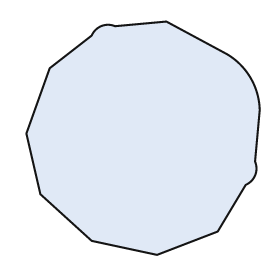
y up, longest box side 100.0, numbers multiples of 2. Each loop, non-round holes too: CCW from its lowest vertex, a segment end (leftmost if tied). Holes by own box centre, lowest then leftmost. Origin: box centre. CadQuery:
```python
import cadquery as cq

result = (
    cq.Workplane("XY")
    .moveTo(6.0, -50.0)
    .lineTo(32.0, -40.0)
    .lineTo(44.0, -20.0)
    .threePointArc((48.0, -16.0), (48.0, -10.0))
    .lineTo(50.0, 12.0)
    .threePointArc((46.0, 26.0), (36.0, 36.0))
    .lineTo(10.0, 50.0)
    .lineTo(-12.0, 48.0)
    .threePointArc((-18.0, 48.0), (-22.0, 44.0))
    .lineTo(-40.0, 30.0)
    .lineTo(-50.0, 2.0)
    .lineTo(-44.0, -24.0)
    .lineTo(-22.0, -44.0)
    .close()
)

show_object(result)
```